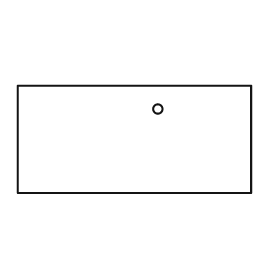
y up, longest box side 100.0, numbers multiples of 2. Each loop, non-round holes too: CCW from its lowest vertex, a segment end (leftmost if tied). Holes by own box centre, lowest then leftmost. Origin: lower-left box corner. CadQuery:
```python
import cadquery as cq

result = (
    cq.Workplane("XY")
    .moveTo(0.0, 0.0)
    .lineTo(100.0, 0.0)
    .lineTo(100.0, 46.0)
    .lineTo(0.0, 46.0)
    .close()
    .moveTo(60.0, 36.0)
    .circle(2.0)
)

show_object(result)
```